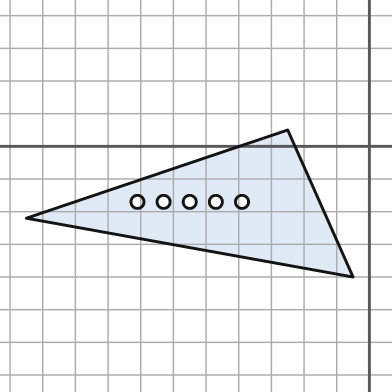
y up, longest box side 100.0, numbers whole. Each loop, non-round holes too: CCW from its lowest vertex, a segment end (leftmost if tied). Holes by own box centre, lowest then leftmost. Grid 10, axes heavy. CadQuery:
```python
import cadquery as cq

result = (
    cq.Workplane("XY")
    .moveTo(-5.0, -40.0)
    .lineTo(-25.0, 5.0)
    .lineTo(-105.0, -22.0)
    .close()
    .moveTo(-71.0, -17.0)
    .circle(2.0)
    .moveTo(-63.0, -17.0)
    .circle(2.0)
    .moveTo(-55.0, -17.0)
    .circle(2.0)
    .moveTo(-47.0, -17.0)
    .circle(2.0)
    .moveTo(-39.0, -17.0)
    .circle(2.0)
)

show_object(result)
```